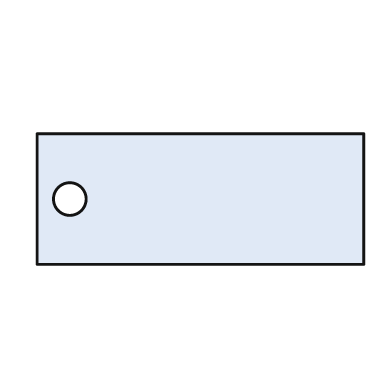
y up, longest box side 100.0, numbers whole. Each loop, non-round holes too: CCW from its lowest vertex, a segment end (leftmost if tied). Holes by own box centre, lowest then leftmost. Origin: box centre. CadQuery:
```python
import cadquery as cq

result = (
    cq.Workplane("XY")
    .moveTo(-50.0, -20.0)
    .lineTo(50.0, -20.0)
    .lineTo(50.0, 20.0)
    .lineTo(-50.0, 20.0)
    .close()
    .moveTo(-40.0, 0.0)
    .circle(5.0)
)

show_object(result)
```